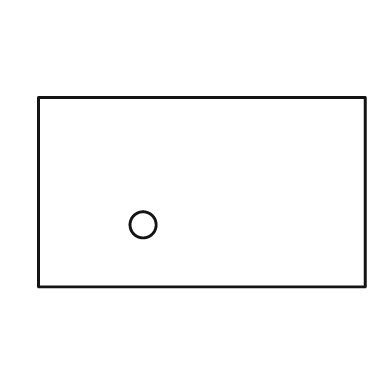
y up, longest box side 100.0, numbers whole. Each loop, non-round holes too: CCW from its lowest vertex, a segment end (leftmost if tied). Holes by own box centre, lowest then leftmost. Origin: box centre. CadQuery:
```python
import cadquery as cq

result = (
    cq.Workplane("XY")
    .moveTo(-50.0, -29.0)
    .lineTo(50.0, -29.0)
    .lineTo(50.0, 29.0)
    .lineTo(-50.0, 29.0)
    .close()
    .moveTo(-18.0, -10.0)
    .circle(4.0)
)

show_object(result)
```